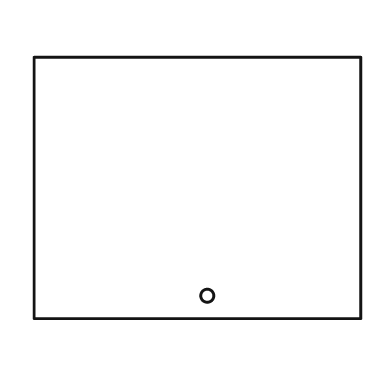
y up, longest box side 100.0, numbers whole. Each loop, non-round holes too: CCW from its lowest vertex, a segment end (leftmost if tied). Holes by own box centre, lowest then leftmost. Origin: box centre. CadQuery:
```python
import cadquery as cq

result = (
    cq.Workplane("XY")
    .moveTo(-50.0, -40.0)
    .lineTo(50.0, -40.0)
    .lineTo(50.0, 40.0)
    .lineTo(-50.0, 40.0)
    .close()
    .moveTo(3.0, -33.0)
    .circle(2.0)
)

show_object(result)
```